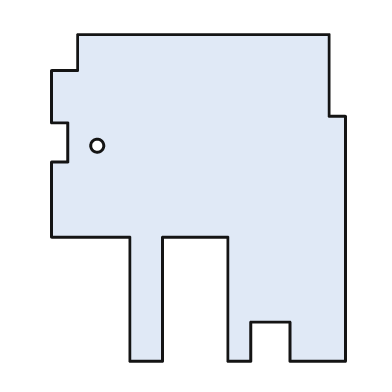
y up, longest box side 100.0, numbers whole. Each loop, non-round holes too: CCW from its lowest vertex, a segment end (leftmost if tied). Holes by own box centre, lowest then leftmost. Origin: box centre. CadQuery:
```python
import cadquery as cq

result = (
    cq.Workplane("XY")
    .moveTo(-21.0, -50.0)
    .lineTo(-11.0, -50.0)
    .lineTo(-11.0, -12.0)
    .lineTo(9.0, -12.0)
    .lineTo(9.0, -50.0)
    .lineTo(16.0, -50.0)
    .lineTo(16.0, -38.0)
    .lineTo(28.0, -38.0)
    .lineTo(28.0, -50.0)
    .lineTo(45.0, -50.0)
    .lineTo(45.0, 25.0)
    .lineTo(40.0, 25.0)
    .lineTo(40.0, 50.0)
    .lineTo(-37.0, 50.0)
    .lineTo(-37.0, 39.0)
    .lineTo(-45.0, 39.0)
    .lineTo(-45.0, 23.0)
    .lineTo(-40.0, 23.0)
    .lineTo(-40.0, 11.0)
    .lineTo(-45.0, 11.0)
    .lineTo(-45.0, -12.0)
    .lineTo(-21.0, -12.0)
    .close()
    .moveTo(-31.0, 16.0)
    .circle(2.0)
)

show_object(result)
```